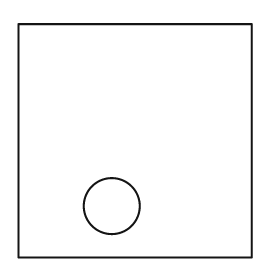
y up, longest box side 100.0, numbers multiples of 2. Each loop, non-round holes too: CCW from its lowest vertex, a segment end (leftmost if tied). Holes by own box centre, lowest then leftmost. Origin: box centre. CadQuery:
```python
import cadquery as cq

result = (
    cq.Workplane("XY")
    .moveTo(-50.0, -50.0)
    .lineTo(50.0, -50.0)
    .lineTo(50.0, 50.0)
    .lineTo(-50.0, 50.0)
    .close()
    .moveTo(-10.0, -28.0)
    .circle(12.0)
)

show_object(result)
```